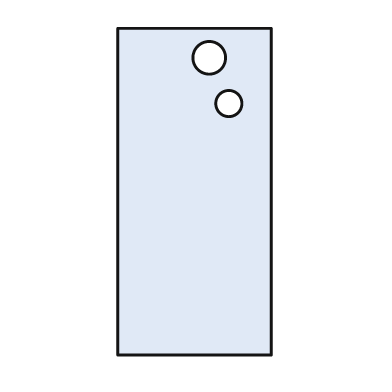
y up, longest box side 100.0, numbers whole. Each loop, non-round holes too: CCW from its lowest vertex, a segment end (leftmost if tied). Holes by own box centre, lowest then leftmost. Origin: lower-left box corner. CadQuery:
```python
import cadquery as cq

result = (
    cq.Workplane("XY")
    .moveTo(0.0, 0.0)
    .lineTo(47.0, 0.0)
    .lineTo(47.0, 100.0)
    .lineTo(0.0, 100.0)
    .close()
    .moveTo(34.0, 77.0)
    .circle(4.0)
    .moveTo(28.0, 91.0)
    .circle(5.0)
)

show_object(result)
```